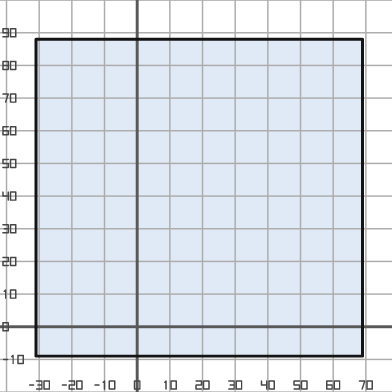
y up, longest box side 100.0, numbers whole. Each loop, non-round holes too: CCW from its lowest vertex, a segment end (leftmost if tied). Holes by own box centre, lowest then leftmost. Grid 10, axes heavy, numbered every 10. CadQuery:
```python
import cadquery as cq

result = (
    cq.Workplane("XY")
    .moveTo(-31.0, -9.0)
    .lineTo(69.0, -9.0)
    .lineTo(69.0, 88.0)
    .lineTo(-31.0, 88.0)
    .close()
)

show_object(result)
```